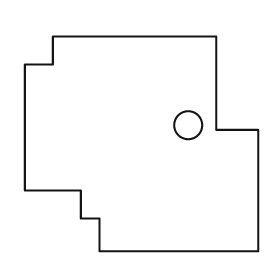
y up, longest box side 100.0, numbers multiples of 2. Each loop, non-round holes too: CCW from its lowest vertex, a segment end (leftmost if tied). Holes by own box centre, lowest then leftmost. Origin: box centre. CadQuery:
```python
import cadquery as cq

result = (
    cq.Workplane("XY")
    .moveTo(-18.0, -46.0)
    .lineTo(50.0, -46.0)
    .lineTo(50.0, 6.0)
    .lineTo(32.0, 6.0)
    .lineTo(32.0, 46.0)
    .lineTo(-38.0, 46.0)
    .lineTo(-38.0, 34.0)
    .lineTo(-50.0, 34.0)
    .lineTo(-50.0, -20.0)
    .lineTo(-26.0, -20.0)
    .lineTo(-26.0, -32.0)
    .lineTo(-18.0, -32.0)
    .close()
    .moveTo(20.0, 8.0)
    .circle(6.0)
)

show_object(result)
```